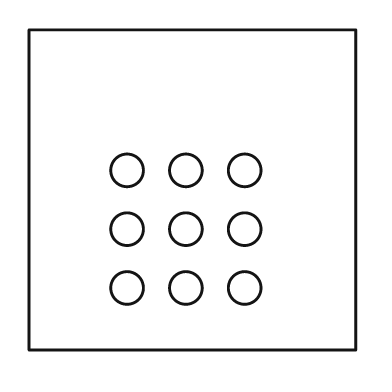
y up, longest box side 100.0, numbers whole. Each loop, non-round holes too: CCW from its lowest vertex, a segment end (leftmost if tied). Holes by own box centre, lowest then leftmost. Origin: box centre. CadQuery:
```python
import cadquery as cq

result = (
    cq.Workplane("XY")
    .moveTo(-50.0, -49.0)
    .lineTo(50.0, -49.0)
    .lineTo(50.0, 49.0)
    .lineTo(-50.0, 49.0)
    .close()
    .moveTo(-20.0, -30.0)
    .circle(5.0)
    .moveTo(-2.0, -30.0)
    .circle(5.0)
    .moveTo(16.0, -30.0)
    .circle(5.0)
    .moveTo(-20.0, -12.0)
    .circle(5.0)
    .moveTo(-2.0, -12.0)
    .circle(5.0)
    .moveTo(16.0, -12.0)
    .circle(5.0)
    .moveTo(-20.0, 6.0)
    .circle(5.0)
    .moveTo(-2.0, 6.0)
    .circle(5.0)
    .moveTo(16.0, 6.0)
    .circle(5.0)
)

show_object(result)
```